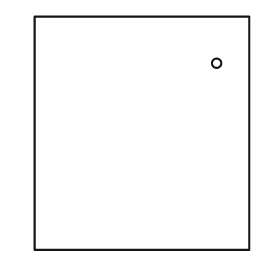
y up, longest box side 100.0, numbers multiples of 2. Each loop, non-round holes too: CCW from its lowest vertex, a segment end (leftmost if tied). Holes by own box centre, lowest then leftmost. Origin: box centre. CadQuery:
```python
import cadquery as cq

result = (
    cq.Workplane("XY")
    .moveTo(-46.0, -50.0)
    .lineTo(46.0, -50.0)
    .lineTo(46.0, 50.0)
    .lineTo(-46.0, 50.0)
    .close()
    .moveTo(32.0, 30.0)
    .circle(2.0)
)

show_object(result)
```